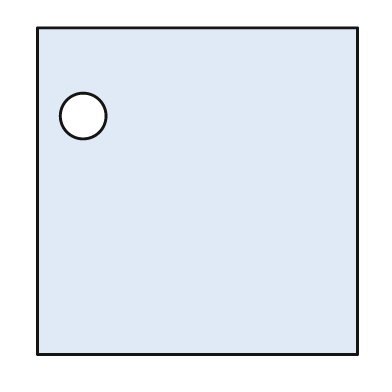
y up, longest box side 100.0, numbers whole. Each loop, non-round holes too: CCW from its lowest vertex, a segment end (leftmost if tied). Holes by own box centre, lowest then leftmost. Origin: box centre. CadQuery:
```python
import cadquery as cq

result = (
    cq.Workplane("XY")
    .moveTo(-49.0, -50.0)
    .lineTo(49.0, -50.0)
    .lineTo(49.0, 50.0)
    .lineTo(-49.0, 50.0)
    .close()
    .moveTo(-35.0, 23.0)
    .circle(7.0)
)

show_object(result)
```